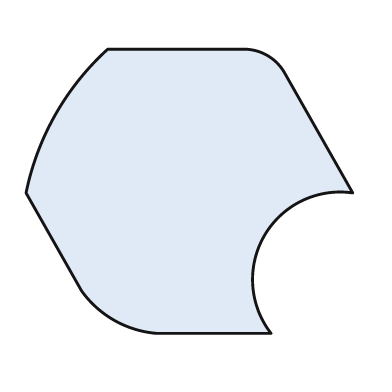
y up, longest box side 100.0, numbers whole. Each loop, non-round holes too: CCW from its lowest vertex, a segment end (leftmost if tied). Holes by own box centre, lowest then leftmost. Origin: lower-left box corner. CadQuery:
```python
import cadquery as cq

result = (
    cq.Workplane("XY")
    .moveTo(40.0, 0.0)
    .lineTo(75.0, 0.0)
    .threePointArc((73.0, 30.0), (100.0, 43.0))
    .lineTo(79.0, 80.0)
    .threePointArc((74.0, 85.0), (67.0, 87.0))
    .lineTo(25.0, 87.0)
    .threePointArc((9.0, 67.0), (0.0, 43.0))
    .lineTo(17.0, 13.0)
    .threePointArc((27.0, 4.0), (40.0, 0.0))
    .close()
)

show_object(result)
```